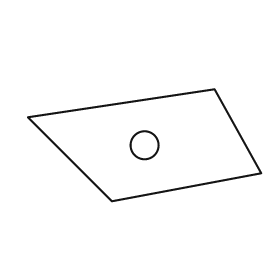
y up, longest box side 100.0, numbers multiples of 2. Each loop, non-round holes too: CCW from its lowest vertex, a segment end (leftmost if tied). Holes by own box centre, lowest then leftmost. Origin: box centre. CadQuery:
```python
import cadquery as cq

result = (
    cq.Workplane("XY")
    .moveTo(-14.0, -24.0)
    .lineTo(50.0, -12.0)
    .lineTo(30.0, 24.0)
    .lineTo(-50.0, 12.0)
    .close()
    .moveTo(0.0, 0.0)
    .circle(6.0)
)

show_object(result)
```